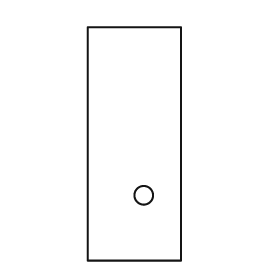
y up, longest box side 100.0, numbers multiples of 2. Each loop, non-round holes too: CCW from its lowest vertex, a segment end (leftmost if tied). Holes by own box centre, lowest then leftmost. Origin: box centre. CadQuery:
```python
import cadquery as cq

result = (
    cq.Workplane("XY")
    .moveTo(-20.0, -50.0)
    .lineTo(20.0, -50.0)
    .lineTo(20.0, 50.0)
    .lineTo(-20.0, 50.0)
    .close()
    .moveTo(4.0, -22.0)
    .circle(4.0)
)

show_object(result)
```